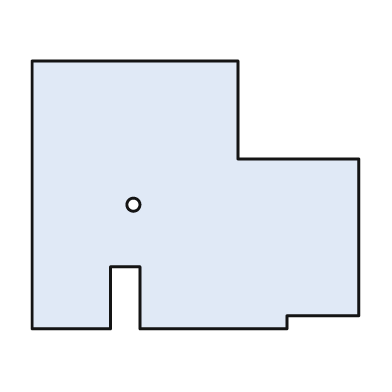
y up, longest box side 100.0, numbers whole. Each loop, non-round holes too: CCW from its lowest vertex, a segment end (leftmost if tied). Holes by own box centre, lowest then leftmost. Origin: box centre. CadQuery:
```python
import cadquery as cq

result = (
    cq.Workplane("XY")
    .moveTo(-50.0, -41.0)
    .lineTo(-26.0, -41.0)
    .lineTo(-26.0, -22.0)
    .lineTo(-17.0, -22.0)
    .lineTo(-17.0, -41.0)
    .lineTo(28.0, -41.0)
    .lineTo(28.0, -37.0)
    .lineTo(50.0, -37.0)
    .lineTo(50.0, 11.0)
    .lineTo(13.0, 11.0)
    .lineTo(13.0, 41.0)
    .lineTo(-50.0, 41.0)
    .close()
    .moveTo(-19.0, -3.0)
    .circle(2.0)
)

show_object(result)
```